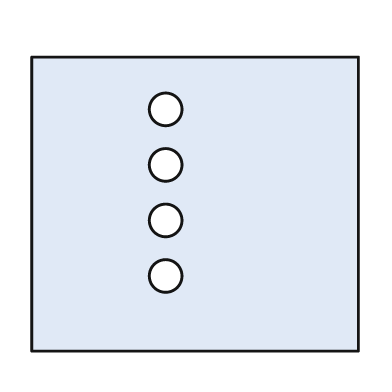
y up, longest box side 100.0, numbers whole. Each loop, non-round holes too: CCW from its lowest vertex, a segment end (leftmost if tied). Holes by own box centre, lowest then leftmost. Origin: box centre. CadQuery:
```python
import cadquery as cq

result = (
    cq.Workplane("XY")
    .moveTo(-50.0, -45.0)
    .lineTo(50.0, -45.0)
    .lineTo(50.0, 45.0)
    .lineTo(-50.0, 45.0)
    .close()
    .moveTo(-9.0, -22.0)
    .circle(5.0)
    .moveTo(-9.0, -5.0)
    .circle(5.0)
    .moveTo(-9.0, 12.0)
    .circle(5.0)
    .moveTo(-9.0, 29.0)
    .circle(5.0)
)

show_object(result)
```